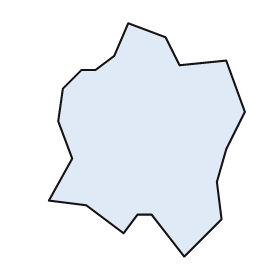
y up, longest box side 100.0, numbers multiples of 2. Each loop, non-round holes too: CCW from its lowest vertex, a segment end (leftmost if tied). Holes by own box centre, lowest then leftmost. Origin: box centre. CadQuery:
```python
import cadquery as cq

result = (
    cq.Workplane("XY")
    .moveTo(16.0, -50.0)
    .lineTo(32.0, -34.0)
    .lineTo(30.0, -18.0)
    .lineTo(34.0, -4.0)
    .lineTo(42.0, 12.0)
    .lineTo(34.0, 34.0)
    .lineTo(14.0, 32.0)
    .lineTo(8.0, 44.0)
    .lineTo(-8.0, 50.0)
    .lineTo(-14.0, 36.0)
    .lineTo(-22.0, 30.0)
    .lineTo(-28.0, 30.0)
    .lineTo(-36.0, 22.0)
    .lineTo(-38.0, 8.0)
    .lineTo(-32.0, -8.0)
    .lineTo(-42.0, -26.0)
    .lineTo(-26.0, -28.0)
    .lineTo(-10.0, -40.0)
    .lineTo(-4.0, -32.0)
    .lineTo(2.0, -32.0)
    .close()
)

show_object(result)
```